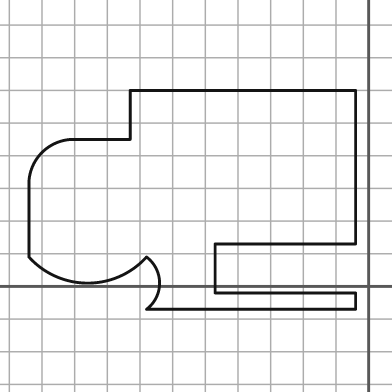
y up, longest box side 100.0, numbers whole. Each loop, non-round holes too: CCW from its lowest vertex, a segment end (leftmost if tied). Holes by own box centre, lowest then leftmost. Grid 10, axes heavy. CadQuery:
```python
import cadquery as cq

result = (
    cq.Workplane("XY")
    .moveTo(-68.0, -7.0)
    .lineTo(-4.0, -7.0)
    .lineTo(-4.0, -2.0)
    .lineTo(-47.0, -2.0)
    .lineTo(-47.0, 13.0)
    .lineTo(-4.0, 13.0)
    .lineTo(-4.0, 60.0)
    .lineTo(-73.0, 60.0)
    .lineTo(-73.0, 45.0)
    .lineTo(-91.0, 45.0)
    .threePointArc((-100.0, 41.0), (-104.0, 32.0))
    .lineTo(-104.0, 9.0)
    .threePointArc((-86.0, 1.0), (-68.0, 9.0))
    .threePointArc((-64.0, 1.0), (-68.0, -7.0))
    .close()
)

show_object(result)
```